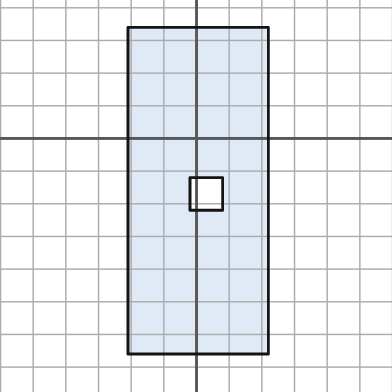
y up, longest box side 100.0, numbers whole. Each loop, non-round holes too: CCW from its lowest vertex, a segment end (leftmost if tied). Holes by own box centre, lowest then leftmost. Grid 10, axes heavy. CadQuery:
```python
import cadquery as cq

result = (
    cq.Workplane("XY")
    .moveTo(-21.0, -66.0)
    .lineTo(22.0, -66.0)
    .lineTo(22.0, 34.0)
    .lineTo(-21.0, 34.0)
    .close()
    .moveTo(-2.0, -22.0)
    .lineTo(8.0, -22.0)
    .lineTo(8.0, -12.0)
    .lineTo(-2.0, -12.0)
    .close()
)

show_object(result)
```